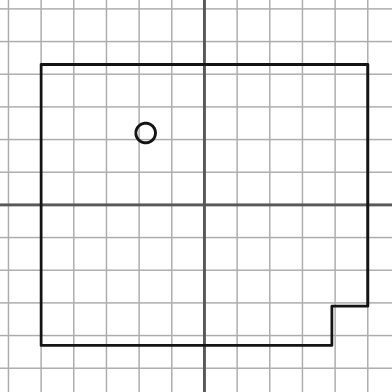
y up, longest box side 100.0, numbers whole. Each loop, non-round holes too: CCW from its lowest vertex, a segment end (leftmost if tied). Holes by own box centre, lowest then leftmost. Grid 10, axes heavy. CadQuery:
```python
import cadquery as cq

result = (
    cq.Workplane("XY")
    .moveTo(-50.0, -43.0)
    .lineTo(39.0, -43.0)
    .lineTo(39.0, -31.0)
    .lineTo(50.0, -31.0)
    .lineTo(50.0, 43.0)
    .lineTo(-50.0, 43.0)
    .close()
    .moveTo(-18.0, 22.0)
    .circle(3.0)
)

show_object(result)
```